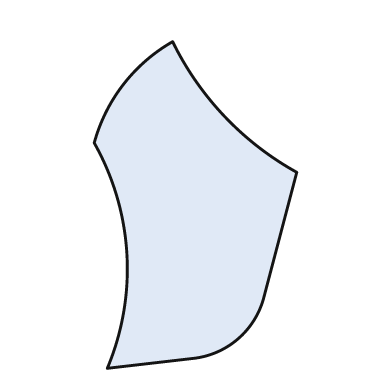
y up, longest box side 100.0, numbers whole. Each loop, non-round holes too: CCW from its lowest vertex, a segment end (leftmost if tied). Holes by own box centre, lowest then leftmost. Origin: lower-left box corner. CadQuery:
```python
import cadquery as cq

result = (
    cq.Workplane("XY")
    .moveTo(4.0, 0.0)
    .lineTo(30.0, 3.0)
    .threePointArc((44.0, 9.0), (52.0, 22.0))
    .lineTo(62.0, 60.0)
    .threePointArc((40.0, 77.0), (24.0, 100.0))
    .threePointArc((9.0, 87.0), (0.0, 69.0))
    .threePointArc((10.0, 35.0), (4.0, 0.0))
    .close()
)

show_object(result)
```